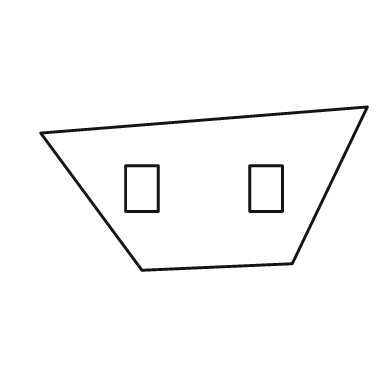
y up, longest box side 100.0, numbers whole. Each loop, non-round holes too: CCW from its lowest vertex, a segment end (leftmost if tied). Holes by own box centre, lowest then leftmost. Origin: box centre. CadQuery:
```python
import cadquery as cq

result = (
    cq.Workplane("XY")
    .moveTo(-19.0, -25.0)
    .lineTo(27.0, -23.0)
    .lineTo(50.0, 25.0)
    .lineTo(-50.0, 17.0)
    .close()
    .moveTo(-24.0, -7.0)
    .lineTo(-14.0, -7.0)
    .lineTo(-14.0, 7.0)
    .lineTo(-24.0, 7.0)
    .close()
    .moveTo(14.0, -7.0)
    .lineTo(24.0, -7.0)
    .lineTo(24.0, 7.0)
    .lineTo(14.0, 7.0)
    .close()
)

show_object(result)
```